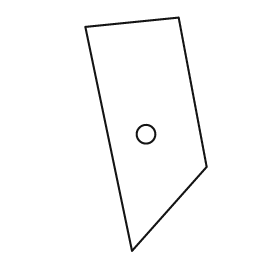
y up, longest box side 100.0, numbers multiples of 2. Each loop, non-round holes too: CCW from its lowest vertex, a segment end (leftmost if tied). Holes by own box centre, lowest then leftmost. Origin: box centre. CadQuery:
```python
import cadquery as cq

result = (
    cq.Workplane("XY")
    .moveTo(-6.0, -50.0)
    .lineTo(26.0, -14.0)
    .lineTo(14.0, 50.0)
    .lineTo(-26.0, 46.0)
    .close()
    .moveTo(0.0, 0.0)
    .circle(4.0)
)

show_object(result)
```